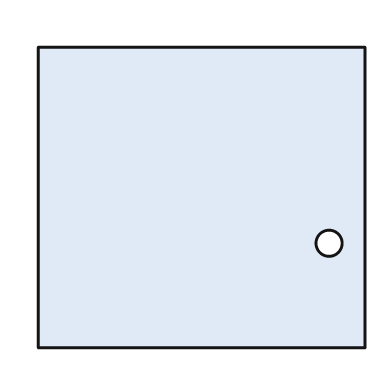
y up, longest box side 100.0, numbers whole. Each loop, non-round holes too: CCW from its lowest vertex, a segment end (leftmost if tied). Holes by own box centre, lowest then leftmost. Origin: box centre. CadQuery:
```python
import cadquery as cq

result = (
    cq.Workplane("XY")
    .moveTo(-50.0, -46.0)
    .lineTo(50.0, -46.0)
    .lineTo(50.0, 46.0)
    .lineTo(-50.0, 46.0)
    .close()
    .moveTo(39.0, -14.0)
    .circle(4.0)
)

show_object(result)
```